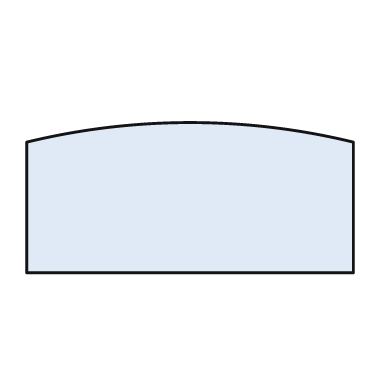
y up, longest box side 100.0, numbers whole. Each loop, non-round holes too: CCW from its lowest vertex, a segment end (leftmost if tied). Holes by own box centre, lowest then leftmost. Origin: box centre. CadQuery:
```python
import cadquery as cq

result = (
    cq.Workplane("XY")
    .moveTo(-50.0, -23.0)
    .lineTo(50.0, -23.0)
    .lineTo(50.0, 17.0)
    .threePointArc((0.0, 23.0), (-50.0, 17.0))
    .close()
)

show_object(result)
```